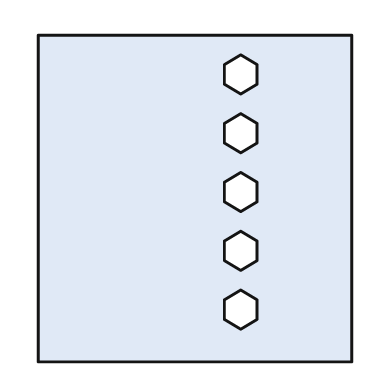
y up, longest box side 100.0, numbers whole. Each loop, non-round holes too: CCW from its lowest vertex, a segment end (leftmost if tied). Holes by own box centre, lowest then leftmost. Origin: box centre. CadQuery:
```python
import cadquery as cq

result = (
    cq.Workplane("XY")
    .moveTo(-48.0, -50.0)
    .lineTo(48.0, -50.0)
    .lineTo(48.0, 50.0)
    .lineTo(-48.0, 50.0)
    .close()
    .moveTo(14.0, -40.0)
    .lineTo(19.0, -37.0)
    .lineTo(19.0, -31.0)
    .lineTo(14.0, -28.0)
    .lineTo(9.0, -31.0)
    .lineTo(9.0, -37.0)
    .close()
    .moveTo(14.0, -22.0)
    .lineTo(19.0, -19.0)
    .lineTo(19.0, -13.0)
    .lineTo(14.0, -10.0)
    .lineTo(9.0, -13.0)
    .lineTo(9.0, -19.0)
    .close()
    .moveTo(14.0, -4.0)
    .lineTo(19.0, -1.0)
    .lineTo(19.0, 5.0)
    .lineTo(14.0, 8.0)
    .lineTo(9.0, 5.0)
    .lineTo(9.0, -1.0)
    .close()
    .moveTo(14.0, 14.0)
    .lineTo(19.0, 17.0)
    .lineTo(19.0, 23.0)
    .lineTo(14.0, 26.0)
    .lineTo(9.0, 23.0)
    .lineTo(9.0, 17.0)
    .close()
    .moveTo(14.0, 32.0)
    .lineTo(19.0, 35.0)
    .lineTo(19.0, 41.0)
    .lineTo(14.0, 44.0)
    .lineTo(9.0, 41.0)
    .lineTo(9.0, 35.0)
    .close()
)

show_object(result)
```